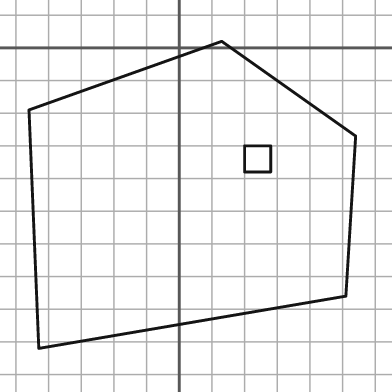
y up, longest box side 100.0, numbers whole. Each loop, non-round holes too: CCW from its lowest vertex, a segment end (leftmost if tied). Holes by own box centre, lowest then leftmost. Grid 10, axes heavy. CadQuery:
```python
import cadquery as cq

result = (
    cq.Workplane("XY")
    .moveTo(-43.0, -92.0)
    .lineTo(51.0, -76.0)
    .lineTo(54.0, -27.0)
    .lineTo(13.0, 2.0)
    .lineTo(-46.0, -19.0)
    .close()
    .moveTo(20.0, -38.0)
    .lineTo(28.0, -38.0)
    .lineTo(28.0, -30.0)
    .lineTo(20.0, -30.0)
    .close()
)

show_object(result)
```